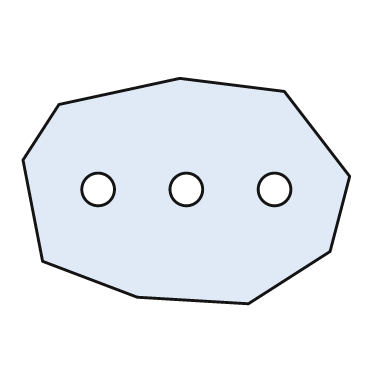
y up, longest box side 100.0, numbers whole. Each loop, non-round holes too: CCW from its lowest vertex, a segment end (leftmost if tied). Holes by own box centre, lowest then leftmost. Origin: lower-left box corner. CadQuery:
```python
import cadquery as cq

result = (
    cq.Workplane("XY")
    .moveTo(69.0, 0.0)
    .lineTo(94.0, 16.0)
    .lineTo(100.0, 39.0)
    .lineTo(80.0, 65.0)
    .lineTo(48.0, 69.0)
    .lineTo(11.0, 61.0)
    .lineTo(0.0, 44.0)
    .lineTo(6.0, 13.0)
    .lineTo(35.0, 2.0)
    .close()
    .moveTo(23.0, 35.0)
    .circle(5.0)
    .moveTo(50.0, 35.0)
    .circle(5.0)
    .moveTo(77.0, 35.0)
    .circle(5.0)
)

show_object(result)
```